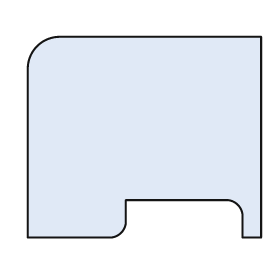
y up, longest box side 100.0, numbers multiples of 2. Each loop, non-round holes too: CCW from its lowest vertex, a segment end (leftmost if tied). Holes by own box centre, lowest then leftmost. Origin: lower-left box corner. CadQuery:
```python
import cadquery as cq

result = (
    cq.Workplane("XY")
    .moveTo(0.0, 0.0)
    .lineTo(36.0, 0.0)
    .threePointArc((40.0, 2.0), (42.0, 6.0))
    .lineTo(42.0, 16.0)
    .lineTo(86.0, 16.0)
    .threePointArc((90.0, 14.0), (92.0, 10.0))
    .lineTo(92.0, 0.0)
    .lineTo(100.0, 0.0)
    .lineTo(100.0, 86.0)
    .lineTo(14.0, 86.0)
    .threePointArc((4.0, 82.0), (0.0, 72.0))
    .close()
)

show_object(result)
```